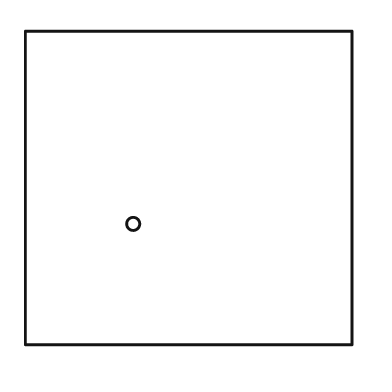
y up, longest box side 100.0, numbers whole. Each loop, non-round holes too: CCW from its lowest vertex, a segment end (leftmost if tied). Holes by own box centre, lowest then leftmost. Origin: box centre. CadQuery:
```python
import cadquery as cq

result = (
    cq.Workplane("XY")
    .moveTo(-50.0, -48.0)
    .lineTo(50.0, -48.0)
    .lineTo(50.0, 48.0)
    .lineTo(-50.0, 48.0)
    .close()
    .moveTo(-17.0, -11.0)
    .circle(2.0)
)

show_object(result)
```